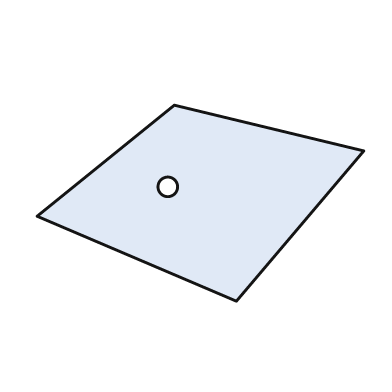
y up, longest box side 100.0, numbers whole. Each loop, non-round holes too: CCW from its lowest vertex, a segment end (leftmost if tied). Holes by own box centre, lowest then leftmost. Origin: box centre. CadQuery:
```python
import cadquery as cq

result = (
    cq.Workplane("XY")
    .moveTo(11.0, -30.0)
    .lineTo(50.0, 16.0)
    .lineTo(-8.0, 30.0)
    .lineTo(-50.0, -4.0)
    .close()
    .moveTo(-10.0, 5.0)
    .circle(3.0)
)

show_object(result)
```